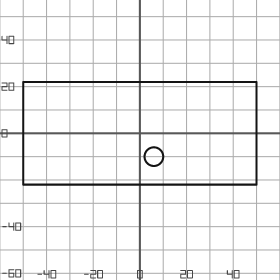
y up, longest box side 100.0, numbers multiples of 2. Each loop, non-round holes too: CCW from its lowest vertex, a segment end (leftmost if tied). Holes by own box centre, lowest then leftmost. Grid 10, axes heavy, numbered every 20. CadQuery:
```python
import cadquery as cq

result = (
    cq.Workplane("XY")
    .moveTo(-50.0, -22.0)
    .lineTo(50.0, -22.0)
    .lineTo(50.0, 22.0)
    .lineTo(-50.0, 22.0)
    .close()
    .moveTo(6.0, -10.0)
    .circle(4.0)
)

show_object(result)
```